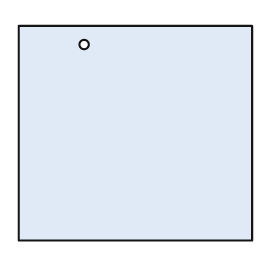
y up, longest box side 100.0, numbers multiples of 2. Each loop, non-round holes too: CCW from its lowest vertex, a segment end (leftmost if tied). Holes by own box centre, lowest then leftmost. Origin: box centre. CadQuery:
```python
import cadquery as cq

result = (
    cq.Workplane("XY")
    .moveTo(-50.0, -46.0)
    .lineTo(50.0, -46.0)
    .lineTo(50.0, 46.0)
    .lineTo(-50.0, 46.0)
    .close()
    .moveTo(-22.0, 38.0)
    .circle(2.0)
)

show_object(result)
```